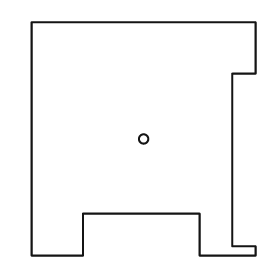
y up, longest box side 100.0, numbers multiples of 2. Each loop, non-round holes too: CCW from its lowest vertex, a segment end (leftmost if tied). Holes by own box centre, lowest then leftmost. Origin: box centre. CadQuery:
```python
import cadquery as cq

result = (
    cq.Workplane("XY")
    .moveTo(-48.0, -50.0)
    .lineTo(-26.0, -50.0)
    .lineTo(-26.0, -32.0)
    .lineTo(24.0, -32.0)
    .lineTo(24.0, -50.0)
    .lineTo(48.0, -50.0)
    .lineTo(48.0, -46.0)
    .lineTo(38.0, -46.0)
    .lineTo(38.0, 28.0)
    .lineTo(48.0, 28.0)
    .lineTo(48.0, 50.0)
    .lineTo(-48.0, 50.0)
    .close()
    .moveTo(0.0, 0.0)
    .circle(2.0)
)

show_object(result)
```